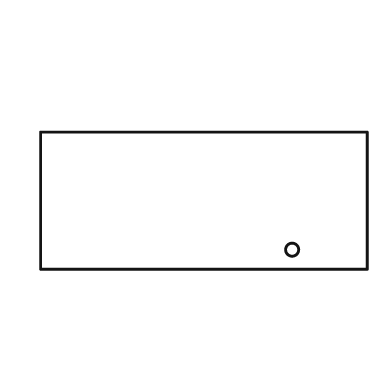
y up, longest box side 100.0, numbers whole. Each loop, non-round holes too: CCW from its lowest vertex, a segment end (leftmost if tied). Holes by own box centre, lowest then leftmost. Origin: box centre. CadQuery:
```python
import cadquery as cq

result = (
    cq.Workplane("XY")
    .moveTo(-50.0, -21.0)
    .lineTo(50.0, -21.0)
    .lineTo(50.0, 21.0)
    .lineTo(-50.0, 21.0)
    .close()
    .moveTo(27.0, -15.0)
    .circle(2.0)
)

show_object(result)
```